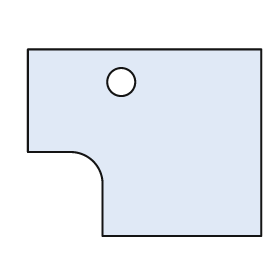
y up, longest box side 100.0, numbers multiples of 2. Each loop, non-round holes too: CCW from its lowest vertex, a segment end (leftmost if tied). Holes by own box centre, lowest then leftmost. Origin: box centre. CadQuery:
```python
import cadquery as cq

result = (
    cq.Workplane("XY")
    .moveTo(-18.0, -40.0)
    .lineTo(50.0, -40.0)
    .lineTo(50.0, 40.0)
    .lineTo(-50.0, 40.0)
    .lineTo(-50.0, -4.0)
    .lineTo(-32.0, -4.0)
    .threePointArc((-22.0, -8.0), (-18.0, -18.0))
    .close()
    .moveTo(-10.0, 26.0)
    .circle(6.0)
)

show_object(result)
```